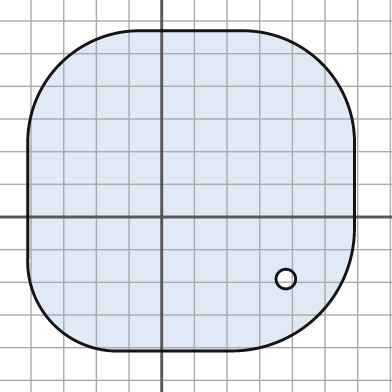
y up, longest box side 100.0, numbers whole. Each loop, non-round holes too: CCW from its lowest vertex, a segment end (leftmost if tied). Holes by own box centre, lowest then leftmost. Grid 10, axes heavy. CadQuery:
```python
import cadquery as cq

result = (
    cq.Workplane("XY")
    .moveTo(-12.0, -41.0)
    .lineTo(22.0, -41.0)
    .threePointArc((48.0, -30.0), (59.0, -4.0))
    .lineTo(59.0, 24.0)
    .threePointArc((49.0, 47.0), (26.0, 57.0))
    .lineTo(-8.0, 57.0)
    .threePointArc((-31.0, 47.0), (-41.0, 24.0))
    .lineTo(-41.0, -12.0)
    .threePointArc((-33.0, -33.0), (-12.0, -41.0))
    .close()
    .moveTo(38.0, -19.0)
    .circle(3.0)
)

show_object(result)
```